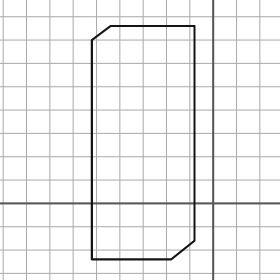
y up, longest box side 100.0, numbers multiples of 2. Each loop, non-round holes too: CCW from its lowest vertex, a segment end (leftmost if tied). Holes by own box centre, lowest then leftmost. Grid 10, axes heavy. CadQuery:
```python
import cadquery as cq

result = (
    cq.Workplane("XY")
    .moveTo(-52.0, -24.0)
    .lineTo(-18.0, -24.0)
    .lineTo(-8.0, -16.0)
    .lineTo(-8.0, 76.0)
    .lineTo(-44.0, 76.0)
    .lineTo(-52.0, 70.0)
    .close()
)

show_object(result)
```